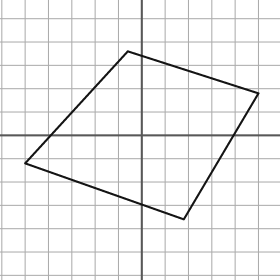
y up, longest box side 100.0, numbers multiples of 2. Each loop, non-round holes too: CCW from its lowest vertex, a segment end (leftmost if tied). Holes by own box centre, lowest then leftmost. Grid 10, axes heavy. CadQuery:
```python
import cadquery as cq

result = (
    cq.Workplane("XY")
    .moveTo(18.0, -36.0)
    .lineTo(50.0, 18.0)
    .lineTo(-6.0, 36.0)
    .lineTo(-50.0, -12.0)
    .close()
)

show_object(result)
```